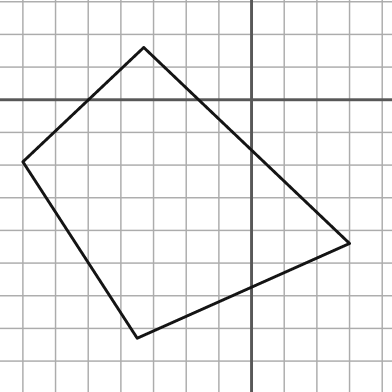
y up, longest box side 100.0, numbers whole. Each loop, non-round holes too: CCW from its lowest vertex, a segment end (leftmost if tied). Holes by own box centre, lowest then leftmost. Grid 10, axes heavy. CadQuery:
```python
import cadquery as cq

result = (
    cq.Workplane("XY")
    .moveTo(-35.0, -73.0)
    .lineTo(30.0, -44.0)
    .lineTo(-33.0, 16.0)
    .lineTo(-70.0, -19.0)
    .close()
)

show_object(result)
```